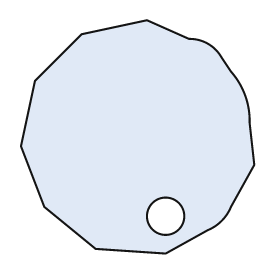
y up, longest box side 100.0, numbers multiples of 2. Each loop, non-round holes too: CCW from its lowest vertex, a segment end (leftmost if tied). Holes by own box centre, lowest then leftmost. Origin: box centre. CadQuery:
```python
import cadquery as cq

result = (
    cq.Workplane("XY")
    .moveTo(12.0, -50.0)
    .lineTo(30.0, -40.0)
    .threePointArc((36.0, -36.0), (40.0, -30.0))
    .lineTo(50.0, -12.0)
    .lineTo(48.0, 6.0)
    .threePointArc((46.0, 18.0), (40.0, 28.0))
    .lineTo(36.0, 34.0)
    .threePointArc((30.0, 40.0), (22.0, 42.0))
    .lineTo(4.0, 50.0)
    .lineTo(-24.0, 44.0)
    .lineTo(-44.0, 24.0)
    .lineTo(-50.0, -4.0)
    .lineTo(-40.0, -30.0)
    .lineTo(-18.0, -48.0)
    .close()
    .moveTo(12.0, -34.0)
    .circle(8.0)
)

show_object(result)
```